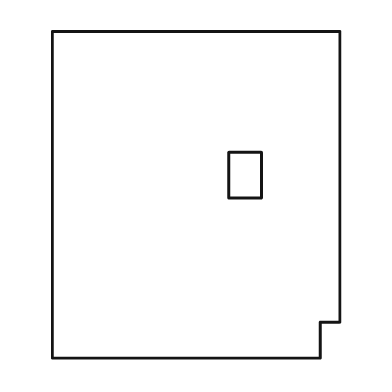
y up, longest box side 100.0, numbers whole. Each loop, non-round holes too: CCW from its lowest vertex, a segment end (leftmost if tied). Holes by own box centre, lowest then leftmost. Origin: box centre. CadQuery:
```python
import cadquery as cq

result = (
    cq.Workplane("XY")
    .moveTo(-44.0, -50.0)
    .lineTo(38.0, -50.0)
    .lineTo(38.0, -39.0)
    .lineTo(44.0, -39.0)
    .lineTo(44.0, 50.0)
    .lineTo(-44.0, 50.0)
    .close()
    .moveTo(10.0, -1.0)
    .lineTo(20.0, -1.0)
    .lineTo(20.0, 13.0)
    .lineTo(10.0, 13.0)
    .close()
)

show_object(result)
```